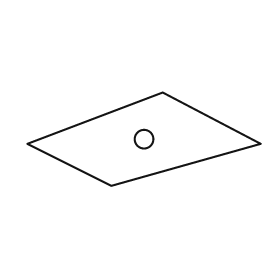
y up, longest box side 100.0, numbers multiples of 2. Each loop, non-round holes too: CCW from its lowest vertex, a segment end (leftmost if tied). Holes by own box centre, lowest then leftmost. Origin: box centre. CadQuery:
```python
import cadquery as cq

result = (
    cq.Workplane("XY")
    .moveTo(-14.0, -20.0)
    .lineTo(50.0, -2.0)
    .lineTo(8.0, 20.0)
    .lineTo(-50.0, -2.0)
    .close()
    .moveTo(0.0, 0.0)
    .circle(4.0)
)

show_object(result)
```